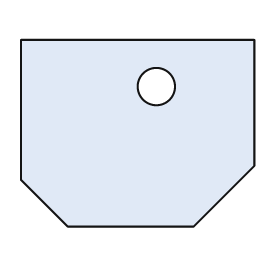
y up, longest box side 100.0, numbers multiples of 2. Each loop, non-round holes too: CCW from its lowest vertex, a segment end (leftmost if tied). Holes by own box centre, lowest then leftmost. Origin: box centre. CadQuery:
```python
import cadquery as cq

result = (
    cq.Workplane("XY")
    .moveTo(-30.0, -40.0)
    .lineTo(24.0, -40.0)
    .lineTo(50.0, -14.0)
    .lineTo(50.0, 40.0)
    .lineTo(-50.0, 40.0)
    .lineTo(-50.0, -20.0)
    .close()
    .moveTo(8.0, 20.0)
    .circle(8.0)
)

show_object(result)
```